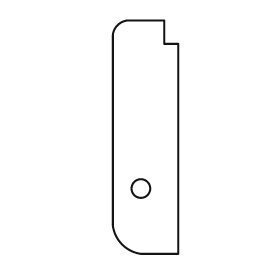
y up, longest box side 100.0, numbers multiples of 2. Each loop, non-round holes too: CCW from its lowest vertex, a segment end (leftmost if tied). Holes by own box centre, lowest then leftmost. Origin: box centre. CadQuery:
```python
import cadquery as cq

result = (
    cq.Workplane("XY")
    .moveTo(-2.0, -50.0)
    .lineTo(14.0, -50.0)
    .lineTo(14.0, 40.0)
    .lineTo(8.0, 40.0)
    .lineTo(8.0, 50.0)
    .lineTo(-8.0, 50.0)
    .threePointArc((-12.0, 48.0), (-14.0, 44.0))
    .lineTo(-14.0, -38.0)
    .threePointArc((-10.0, -46.0), (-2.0, -50.0))
    .close()
    .moveTo(-2.0, -22.0)
    .circle(4.0)
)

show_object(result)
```